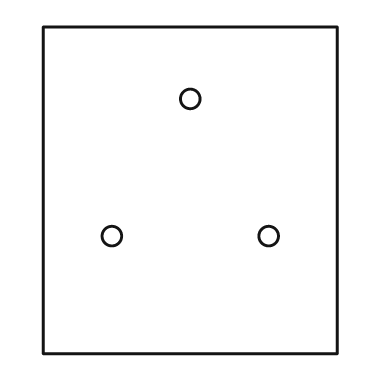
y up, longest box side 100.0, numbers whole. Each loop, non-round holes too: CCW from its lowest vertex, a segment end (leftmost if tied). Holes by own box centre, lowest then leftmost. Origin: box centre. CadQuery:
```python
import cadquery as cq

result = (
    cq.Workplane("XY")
    .moveTo(-45.0, -50.0)
    .lineTo(45.0, -50.0)
    .lineTo(45.0, 50.0)
    .lineTo(-45.0, 50.0)
    .close()
    .moveTo(-24.0, -14.0)
    .circle(3.0)
    .moveTo(24.0, -14.0)
    .circle(3.0)
    .moveTo(0.0, 28.0)
    .circle(3.0)
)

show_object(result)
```